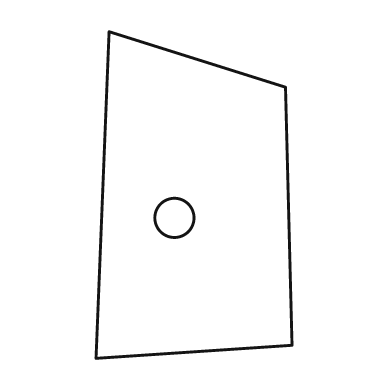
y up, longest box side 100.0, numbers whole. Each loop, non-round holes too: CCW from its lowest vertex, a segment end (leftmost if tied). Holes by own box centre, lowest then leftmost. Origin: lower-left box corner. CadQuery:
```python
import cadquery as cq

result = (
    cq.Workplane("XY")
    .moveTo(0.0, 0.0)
    .lineTo(60.0, 4.0)
    .lineTo(58.0, 83.0)
    .lineTo(4.0, 100.0)
    .close()
    .moveTo(24.0, 43.0)
    .circle(6.0)
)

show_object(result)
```